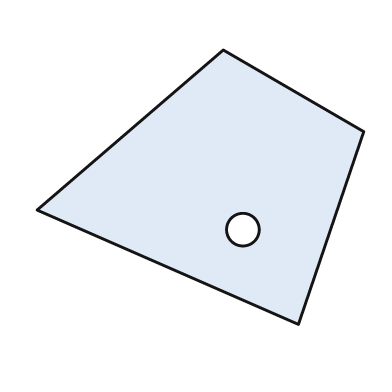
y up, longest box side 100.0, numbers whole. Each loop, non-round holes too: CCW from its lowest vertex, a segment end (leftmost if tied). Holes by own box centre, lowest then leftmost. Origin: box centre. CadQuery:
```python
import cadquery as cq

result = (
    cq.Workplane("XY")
    .moveTo(30.0, -42.0)
    .lineTo(50.0, 17.0)
    .lineTo(7.0, 42.0)
    .lineTo(-50.0, -7.0)
    .close()
    .moveTo(13.0, -13.0)
    .circle(5.0)
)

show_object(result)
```